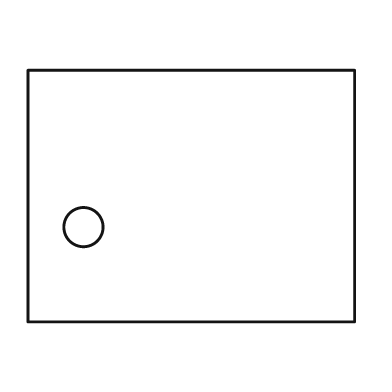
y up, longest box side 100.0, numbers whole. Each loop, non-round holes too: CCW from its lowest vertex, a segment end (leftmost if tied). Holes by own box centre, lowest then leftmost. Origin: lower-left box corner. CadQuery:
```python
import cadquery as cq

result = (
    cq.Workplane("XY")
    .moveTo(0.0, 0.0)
    .lineTo(100.0, 0.0)
    .lineTo(100.0, 77.0)
    .lineTo(0.0, 77.0)
    .close()
    .moveTo(17.0, 29.0)
    .circle(6.0)
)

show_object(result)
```